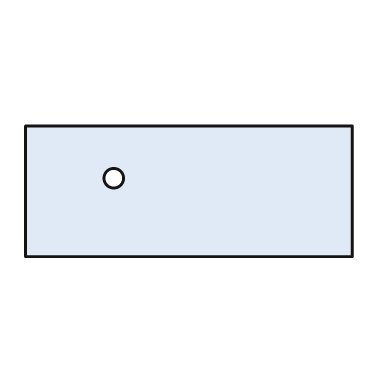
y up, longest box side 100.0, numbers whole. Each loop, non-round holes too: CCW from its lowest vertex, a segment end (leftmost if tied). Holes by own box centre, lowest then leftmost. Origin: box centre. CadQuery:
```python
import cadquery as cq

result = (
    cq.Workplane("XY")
    .moveTo(-50.0, -20.0)
    .lineTo(50.0, -20.0)
    .lineTo(50.0, 20.0)
    .lineTo(-50.0, 20.0)
    .close()
    .moveTo(-23.0, 4.0)
    .circle(3.0)
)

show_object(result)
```